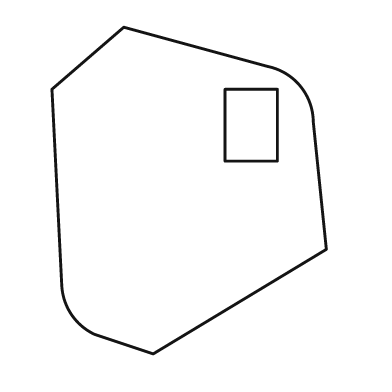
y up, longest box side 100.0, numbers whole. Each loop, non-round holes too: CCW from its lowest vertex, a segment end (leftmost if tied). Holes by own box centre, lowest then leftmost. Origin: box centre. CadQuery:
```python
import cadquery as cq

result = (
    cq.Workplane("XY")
    .moveTo(-11.0, -50.0)
    .lineTo(42.0, -18.0)
    .lineTo(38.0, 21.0)
    .threePointArc((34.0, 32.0), (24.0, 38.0))
    .lineTo(-20.0, 50.0)
    .lineTo(-42.0, 31.0)
    .lineTo(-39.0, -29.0)
    .threePointArc((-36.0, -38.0), (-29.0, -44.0))
    .close()
    .moveTo(11.0, 9.0)
    .lineTo(27.0, 9.0)
    .lineTo(27.0, 31.0)
    .lineTo(11.0, 31.0)
    .close()
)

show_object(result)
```